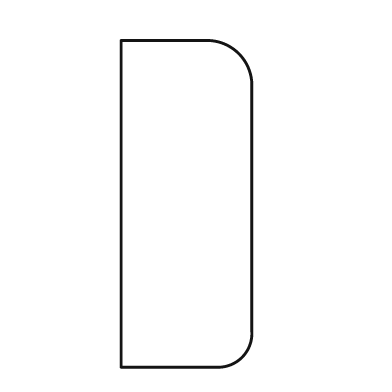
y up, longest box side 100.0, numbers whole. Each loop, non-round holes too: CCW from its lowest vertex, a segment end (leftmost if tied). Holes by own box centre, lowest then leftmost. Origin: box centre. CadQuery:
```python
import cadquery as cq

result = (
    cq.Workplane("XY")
    .moveTo(-20.0, -50.0)
    .lineTo(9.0, -50.0)
    .threePointArc((17.0, -47.0), (20.0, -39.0))
    .lineTo(20.0, 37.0)
    .threePointArc((16.0, 46.0), (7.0, 50.0))
    .lineTo(-20.0, 50.0)
    .close()
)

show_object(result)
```